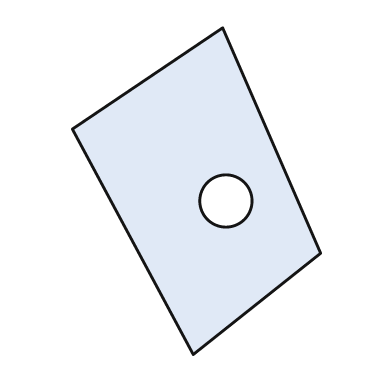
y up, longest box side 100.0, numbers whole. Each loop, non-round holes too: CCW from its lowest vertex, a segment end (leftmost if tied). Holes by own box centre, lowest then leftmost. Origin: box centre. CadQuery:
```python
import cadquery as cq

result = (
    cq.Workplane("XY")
    .moveTo(-1.0, -50.0)
    .lineTo(38.0, -19.0)
    .lineTo(8.0, 50.0)
    .lineTo(-38.0, 19.0)
    .close()
    .moveTo(9.0, -3.0)
    .circle(8.0)
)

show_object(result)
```